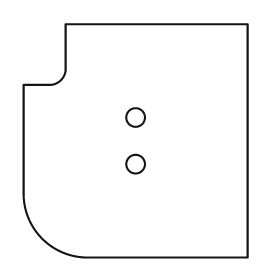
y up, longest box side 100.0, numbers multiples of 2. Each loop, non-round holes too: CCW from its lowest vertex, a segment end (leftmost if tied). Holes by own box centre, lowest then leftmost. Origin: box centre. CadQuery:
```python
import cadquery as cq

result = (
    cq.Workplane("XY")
    .moveTo(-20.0, -50.0)
    .lineTo(48.0, -50.0)
    .lineTo(48.0, 50.0)
    .lineTo(-30.0, 50.0)
    .lineTo(-30.0, 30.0)
    .threePointArc((-32.0, 26.0), (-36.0, 24.0))
    .lineTo(-48.0, 24.0)
    .lineTo(-48.0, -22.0)
    .threePointArc((-40.0, -42.0), (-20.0, -50.0))
    .close()
    .moveTo(0.0, -10.0)
    .circle(4.0)
    .moveTo(0.0, 10.0)
    .circle(4.0)
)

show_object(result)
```